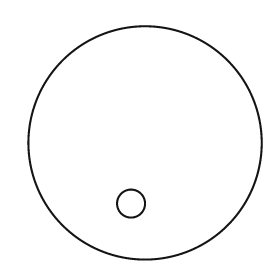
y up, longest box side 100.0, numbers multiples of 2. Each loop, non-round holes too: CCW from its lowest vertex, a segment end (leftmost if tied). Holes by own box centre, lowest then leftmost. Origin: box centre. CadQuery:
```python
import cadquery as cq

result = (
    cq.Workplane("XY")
    .moveTo(0.0, 0.0)
    .circle(50.0)
    .moveTo(-6.0, -26.0)
    .circle(6.0)
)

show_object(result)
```